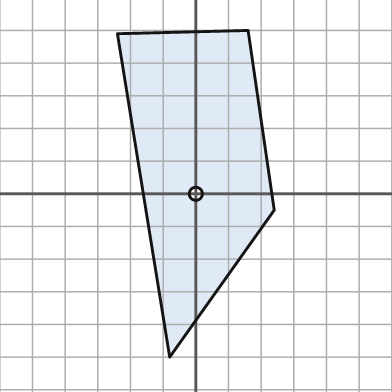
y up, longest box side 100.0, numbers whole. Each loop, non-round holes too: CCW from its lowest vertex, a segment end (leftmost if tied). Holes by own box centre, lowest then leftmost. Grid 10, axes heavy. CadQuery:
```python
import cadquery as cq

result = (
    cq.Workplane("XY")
    .moveTo(-8.0, -50.0)
    .lineTo(24.0, -5.0)
    .lineTo(16.0, 50.0)
    .lineTo(-24.0, 49.0)
    .close()
    .moveTo(0.0, 0.0)
    .circle(2.0)
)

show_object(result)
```